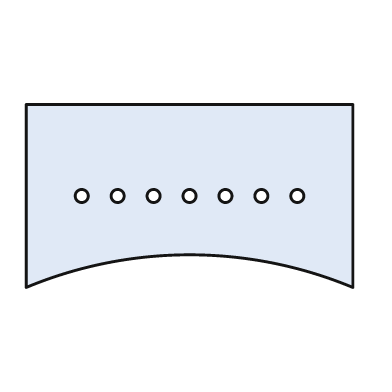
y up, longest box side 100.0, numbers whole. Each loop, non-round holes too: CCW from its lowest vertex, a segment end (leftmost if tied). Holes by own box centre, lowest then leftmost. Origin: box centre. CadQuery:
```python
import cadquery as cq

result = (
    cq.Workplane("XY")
    .moveTo(-50.0, -28.0)
    .threePointArc((0.0, -18.0), (50.0, -28.0))
    .lineTo(50.0, 28.0)
    .lineTo(-50.0, 28.0)
    .close()
    .moveTo(-33.0, 0.0)
    .circle(2.0)
    .moveTo(-22.0, 0.0)
    .circle(2.0)
    .moveTo(-11.0, 0.0)
    .circle(2.0)
    .moveTo(0.0, 0.0)
    .circle(2.0)
    .moveTo(11.0, 0.0)
    .circle(2.0)
    .moveTo(22.0, 0.0)
    .circle(2.0)
    .moveTo(33.0, 0.0)
    .circle(2.0)
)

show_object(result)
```